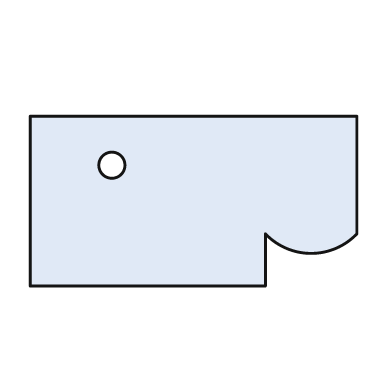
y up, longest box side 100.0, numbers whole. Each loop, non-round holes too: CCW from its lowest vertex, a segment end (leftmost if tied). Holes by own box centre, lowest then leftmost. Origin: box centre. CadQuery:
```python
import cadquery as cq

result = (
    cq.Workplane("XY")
    .moveTo(-50.0, -26.0)
    .lineTo(22.0, -26.0)
    .lineTo(22.0, -10.0)
    .threePointArc((36.0, -16.0), (50.0, -10.0))
    .lineTo(50.0, 26.0)
    .lineTo(-50.0, 26.0)
    .close()
    .moveTo(-25.0, 11.0)
    .circle(4.0)
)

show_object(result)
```